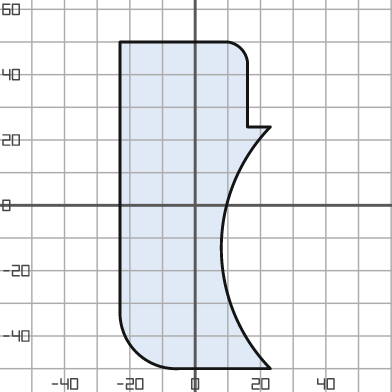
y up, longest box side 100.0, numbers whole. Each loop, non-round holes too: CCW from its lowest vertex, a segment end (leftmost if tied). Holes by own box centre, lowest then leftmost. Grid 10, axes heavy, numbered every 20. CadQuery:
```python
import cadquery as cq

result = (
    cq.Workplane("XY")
    .moveTo(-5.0, -50.0)
    .lineTo(23.0, -50.0)
    .threePointArc((8.0, -13.0), (23.0, 24.0))
    .lineTo(16.0, 24.0)
    .lineTo(16.0, 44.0)
    .threePointArc((14.0, 48.0), (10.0, 50.0))
    .lineTo(-23.0, 50.0)
    .lineTo(-23.0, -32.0)
    .threePointArc((-18.0, -45.0), (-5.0, -50.0))
    .close()
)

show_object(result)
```